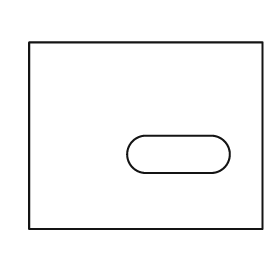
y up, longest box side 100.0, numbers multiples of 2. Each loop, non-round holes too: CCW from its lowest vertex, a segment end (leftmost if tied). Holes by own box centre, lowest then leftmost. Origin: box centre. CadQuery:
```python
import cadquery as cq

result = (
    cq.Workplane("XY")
    .moveTo(-50.0, -40.0)
    .lineTo(50.0, -40.0)
    .lineTo(50.0, 40.0)
    .lineTo(-50.0, 40.0)
    .close()
    .moveTo(0.0, -16.0)
    .lineTo(28.0, -16.0)
    .threePointArc((36.0, -8.0), (28.0, 0.0))
    .lineTo(0.0, 0.0)
    .threePointArc((-8.0, -8.0), (0.0, -16.0))
    .close()
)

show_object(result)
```